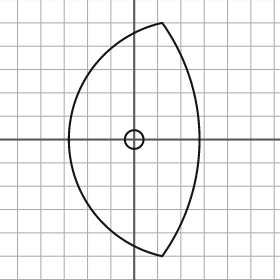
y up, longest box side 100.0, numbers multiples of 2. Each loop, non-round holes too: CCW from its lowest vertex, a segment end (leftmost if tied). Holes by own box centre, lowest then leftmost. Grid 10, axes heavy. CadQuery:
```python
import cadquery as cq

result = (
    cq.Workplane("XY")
    .moveTo(12.0, -50.0)
    .threePointArc((28.0, 0.0), (12.0, 50.0))
    .threePointArc((-28.0, 0.0), (12.0, -50.0))
    .close()
    .moveTo(0.0, 0.0)
    .circle(4.0)
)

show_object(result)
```